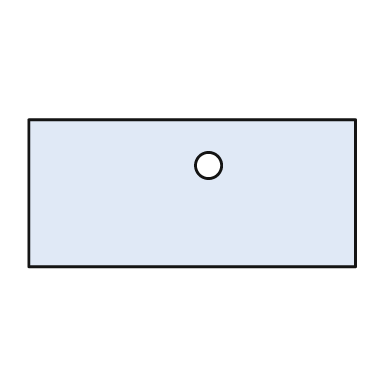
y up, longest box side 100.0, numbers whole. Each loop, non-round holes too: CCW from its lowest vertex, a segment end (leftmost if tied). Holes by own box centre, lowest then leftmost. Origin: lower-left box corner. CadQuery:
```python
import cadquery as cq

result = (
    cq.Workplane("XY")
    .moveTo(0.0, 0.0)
    .lineTo(100.0, 0.0)
    .lineTo(100.0, 45.0)
    .lineTo(0.0, 45.0)
    .close()
    .moveTo(55.0, 31.0)
    .circle(4.0)
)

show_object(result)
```